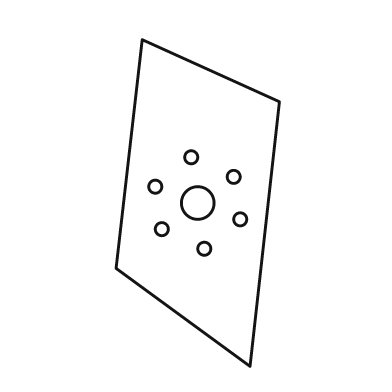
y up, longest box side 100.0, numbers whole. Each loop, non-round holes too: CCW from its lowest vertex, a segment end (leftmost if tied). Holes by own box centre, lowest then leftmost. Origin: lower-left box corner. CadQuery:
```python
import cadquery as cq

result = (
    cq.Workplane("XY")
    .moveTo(41.0, 0.0)
    .lineTo(50.0, 81.0)
    .lineTo(8.0, 100.0)
    .lineTo(0.0, 30.0)
    .close()
    .moveTo(27.0, 36.0)
    .circle(2.0)
    .moveTo(14.0, 42.0)
    .circle(2.0)
    .moveTo(38.0, 45.0)
    .circle(2.0)
    .moveTo(25.0, 50.0)
    .circle(5.0)
    .moveTo(12.0, 55.0)
    .circle(2.0)
    .moveTo(36.0, 58.0)
    .circle(2.0)
    .moveTo(23.0, 64.0)
    .circle(2.0)
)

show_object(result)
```